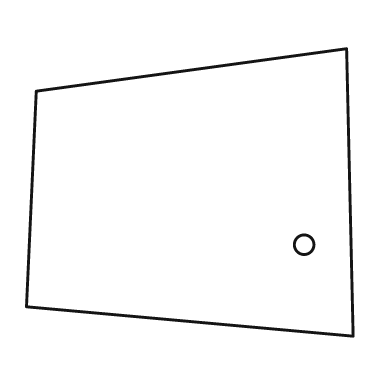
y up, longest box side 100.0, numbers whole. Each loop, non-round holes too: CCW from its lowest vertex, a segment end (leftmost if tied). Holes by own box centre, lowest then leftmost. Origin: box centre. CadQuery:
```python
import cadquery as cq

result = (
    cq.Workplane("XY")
    .moveTo(50.0, -44.0)
    .lineTo(48.0, 44.0)
    .lineTo(-47.0, 31.0)
    .lineTo(-50.0, -35.0)
    .close()
    .moveTo(35.0, -16.0)
    .circle(3.0)
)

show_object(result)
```